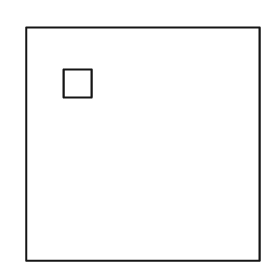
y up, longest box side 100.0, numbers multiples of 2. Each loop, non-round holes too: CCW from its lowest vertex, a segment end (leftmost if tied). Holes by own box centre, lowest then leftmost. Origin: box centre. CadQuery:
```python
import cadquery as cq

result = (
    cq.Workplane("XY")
    .moveTo(-50.0, -50.0)
    .lineTo(50.0, -50.0)
    .lineTo(50.0, 50.0)
    .lineTo(-50.0, 50.0)
    .close()
    .moveTo(-34.0, 20.0)
    .lineTo(-22.0, 20.0)
    .lineTo(-22.0, 32.0)
    .lineTo(-34.0, 32.0)
    .close()
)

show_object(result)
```